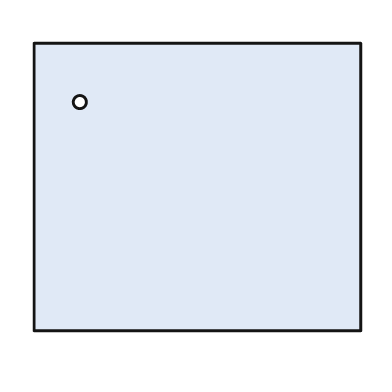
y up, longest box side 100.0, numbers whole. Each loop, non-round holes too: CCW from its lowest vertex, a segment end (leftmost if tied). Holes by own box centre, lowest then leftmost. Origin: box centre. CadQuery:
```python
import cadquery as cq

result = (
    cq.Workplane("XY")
    .moveTo(-50.0, -44.0)
    .lineTo(50.0, -44.0)
    .lineTo(50.0, 44.0)
    .lineTo(-50.0, 44.0)
    .close()
    .moveTo(-36.0, 26.0)
    .circle(2.0)
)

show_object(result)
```